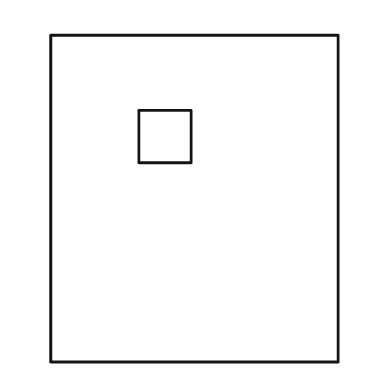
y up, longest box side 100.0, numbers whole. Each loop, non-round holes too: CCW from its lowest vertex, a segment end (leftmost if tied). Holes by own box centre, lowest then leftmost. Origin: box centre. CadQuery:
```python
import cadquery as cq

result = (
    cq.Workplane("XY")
    .moveTo(-44.0, -50.0)
    .lineTo(44.0, -50.0)
    .lineTo(44.0, 50.0)
    .lineTo(-44.0, 50.0)
    .close()
    .moveTo(-17.0, 11.0)
    .lineTo(-1.0, 11.0)
    .lineTo(-1.0, 27.0)
    .lineTo(-17.0, 27.0)
    .close()
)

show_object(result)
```